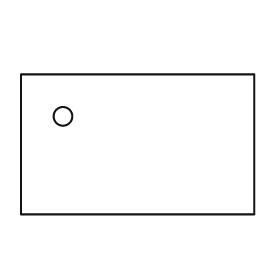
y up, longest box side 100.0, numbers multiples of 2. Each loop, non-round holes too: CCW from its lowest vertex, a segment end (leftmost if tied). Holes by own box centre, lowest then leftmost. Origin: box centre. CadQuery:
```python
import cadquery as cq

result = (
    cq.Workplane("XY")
    .moveTo(-50.0, -30.0)
    .lineTo(50.0, -30.0)
    .lineTo(50.0, 30.0)
    .lineTo(-50.0, 30.0)
    .close()
    .moveTo(-32.0, 12.0)
    .circle(4.0)
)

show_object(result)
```